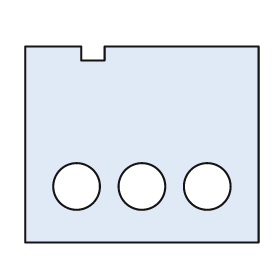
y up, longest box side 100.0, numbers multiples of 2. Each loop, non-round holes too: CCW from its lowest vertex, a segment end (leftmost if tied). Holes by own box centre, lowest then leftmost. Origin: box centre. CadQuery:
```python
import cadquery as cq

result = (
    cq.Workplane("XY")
    .moveTo(-50.0, -42.0)
    .lineTo(50.0, -42.0)
    .lineTo(50.0, 42.0)
    .lineTo(-16.0, 42.0)
    .lineTo(-16.0, 36.0)
    .lineTo(-26.0, 36.0)
    .lineTo(-26.0, 42.0)
    .lineTo(-50.0, 42.0)
    .close()
    .moveTo(-28.0, -18.0)
    .circle(10.0)
    .moveTo(0.0, -18.0)
    .circle(10.0)
    .moveTo(28.0, -18.0)
    .circle(10.0)
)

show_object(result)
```